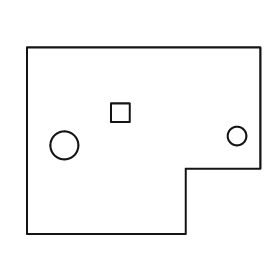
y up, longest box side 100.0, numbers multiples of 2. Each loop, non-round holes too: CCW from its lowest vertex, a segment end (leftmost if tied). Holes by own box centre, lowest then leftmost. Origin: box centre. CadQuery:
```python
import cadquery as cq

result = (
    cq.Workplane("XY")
    .moveTo(-50.0, -40.0)
    .lineTo(18.0, -40.0)
    .lineTo(18.0, -12.0)
    .lineTo(50.0, -12.0)
    .lineTo(50.0, 40.0)
    .lineTo(-50.0, 40.0)
    .close()
    .moveTo(-34.0, -2.0)
    .circle(6.0)
    .moveTo(40.0, 2.0)
    .circle(4.0)
    .moveTo(-14.0, 8.0)
    .lineTo(-6.0, 8.0)
    .lineTo(-6.0, 16.0)
    .lineTo(-14.0, 16.0)
    .close()
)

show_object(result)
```